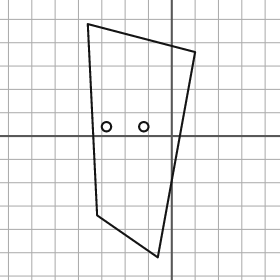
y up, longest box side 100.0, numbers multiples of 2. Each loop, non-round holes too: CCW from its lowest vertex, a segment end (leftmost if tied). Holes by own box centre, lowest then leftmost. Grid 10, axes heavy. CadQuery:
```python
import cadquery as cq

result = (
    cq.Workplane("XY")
    .moveTo(-6.0, -52.0)
    .lineTo(10.0, 36.0)
    .lineTo(-36.0, 48.0)
    .lineTo(-32.0, -34.0)
    .close()
    .moveTo(-28.0, 4.0)
    .circle(2.0)
    .moveTo(-12.0, 4.0)
    .circle(2.0)
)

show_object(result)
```